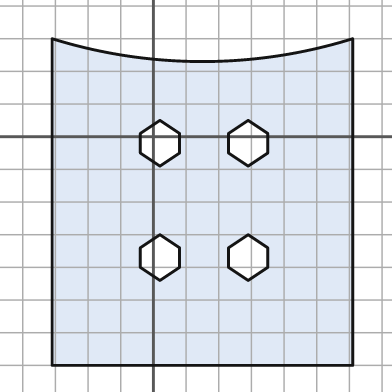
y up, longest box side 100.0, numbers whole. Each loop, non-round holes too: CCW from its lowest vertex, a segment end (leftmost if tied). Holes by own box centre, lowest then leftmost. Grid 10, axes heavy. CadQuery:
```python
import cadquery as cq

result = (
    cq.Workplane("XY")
    .moveTo(-31.0, -70.0)
    .lineTo(61.0, -70.0)
    .lineTo(61.0, 30.0)
    .threePointArc((15.0, 23.0), (-31.0, 30.0))
    .close()
    .moveTo(2.0, -44.0)
    .lineTo(8.0, -40.0)
    .lineTo(8.0, -34.0)
    .lineTo(2.0, -30.0)
    .lineTo(-4.0, -34.0)
    .lineTo(-4.0, -40.0)
    .close()
    .moveTo(29.0, -44.0)
    .lineTo(35.0, -40.0)
    .lineTo(35.0, -34.0)
    .lineTo(29.0, -30.0)
    .lineTo(23.0, -34.0)
    .lineTo(23.0, -40.0)
    .close()
    .moveTo(2.0, -9.0)
    .lineTo(8.0, -5.0)
    .lineTo(8.0, 1.0)
    .lineTo(2.0, 5.0)
    .lineTo(-4.0, 1.0)
    .lineTo(-4.0, -5.0)
    .close()
    .moveTo(29.0, -9.0)
    .lineTo(35.0, -5.0)
    .lineTo(35.0, 1.0)
    .lineTo(29.0, 5.0)
    .lineTo(23.0, 1.0)
    .lineTo(23.0, -5.0)
    .close()
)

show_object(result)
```